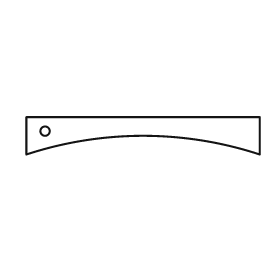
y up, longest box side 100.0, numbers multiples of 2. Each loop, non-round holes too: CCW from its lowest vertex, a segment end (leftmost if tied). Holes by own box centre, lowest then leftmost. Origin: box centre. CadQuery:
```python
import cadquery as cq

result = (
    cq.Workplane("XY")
    .moveTo(-50.0, -8.0)
    .threePointArc((0.0, 0.0), (50.0, -8.0))
    .lineTo(50.0, 8.0)
    .lineTo(-50.0, 8.0)
    .close()
    .moveTo(-42.0, 2.0)
    .circle(2.0)
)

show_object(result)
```